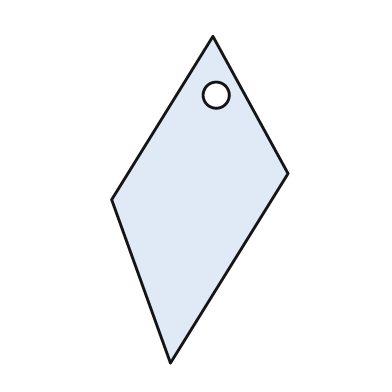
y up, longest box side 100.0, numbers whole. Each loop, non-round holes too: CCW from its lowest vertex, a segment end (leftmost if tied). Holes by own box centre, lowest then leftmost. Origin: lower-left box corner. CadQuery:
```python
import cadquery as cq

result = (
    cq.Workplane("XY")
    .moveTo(18.0, 0.0)
    .lineTo(54.0, 58.0)
    .lineTo(31.0, 100.0)
    .lineTo(0.0, 50.0)
    .close()
    .moveTo(32.0, 82.0)
    .circle(4.0)
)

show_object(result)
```